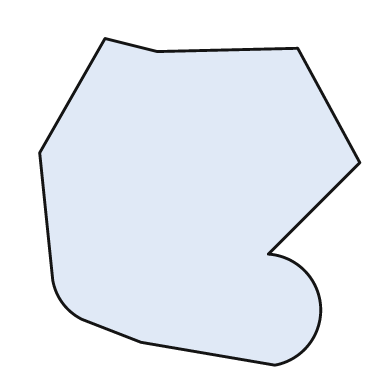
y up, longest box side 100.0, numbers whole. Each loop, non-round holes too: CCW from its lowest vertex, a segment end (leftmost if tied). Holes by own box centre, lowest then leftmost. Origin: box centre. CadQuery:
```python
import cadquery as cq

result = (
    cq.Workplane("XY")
    .moveTo(23.0, -50.0)
    .threePointArc((37.0, -32.0), (21.0, -16.0))
    .lineTo(49.0, 12.0)
    .lineTo(30.0, 47.0)
    .lineTo(-13.0, 46.0)
    .lineTo(-29.0, 50.0)
    .lineTo(-49.0, 15.0)
    .lineTo(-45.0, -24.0)
    .threePointArc((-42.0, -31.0), (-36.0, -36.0))
    .lineTo(-18.0, -43.0)
    .close()
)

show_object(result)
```